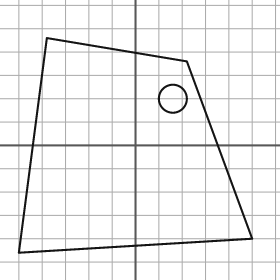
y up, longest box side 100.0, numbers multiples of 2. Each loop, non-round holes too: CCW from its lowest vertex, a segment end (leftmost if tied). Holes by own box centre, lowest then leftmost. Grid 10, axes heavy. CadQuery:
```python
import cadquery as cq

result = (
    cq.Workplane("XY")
    .moveTo(-50.0, -46.0)
    .lineTo(50.0, -40.0)
    .lineTo(22.0, 36.0)
    .lineTo(-38.0, 46.0)
    .close()
    .moveTo(16.0, 20.0)
    .circle(6.0)
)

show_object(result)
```